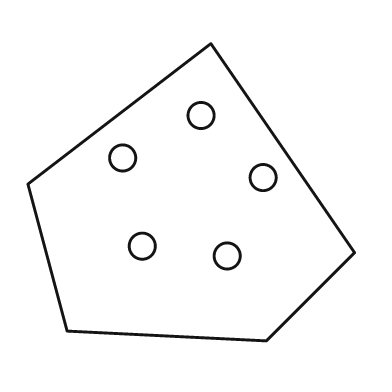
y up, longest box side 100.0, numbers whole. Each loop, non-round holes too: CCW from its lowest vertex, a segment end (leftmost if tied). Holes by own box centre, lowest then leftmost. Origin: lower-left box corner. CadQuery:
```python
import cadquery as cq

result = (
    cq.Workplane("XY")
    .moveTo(73.0, 0.0)
    .lineTo(100.0, 27.0)
    .lineTo(56.0, 91.0)
    .lineTo(0.0, 48.0)
    .lineTo(12.0, 3.0)
    .close()
    .moveTo(61.0, 26.0)
    .circle(4.0)
    .moveTo(35.0, 29.0)
    .circle(4.0)
    .moveTo(72.0, 50.0)
    .circle(4.0)
    .moveTo(29.0, 56.0)
    .circle(4.0)
    .moveTo(53.0, 69.0)
    .circle(4.0)
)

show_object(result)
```